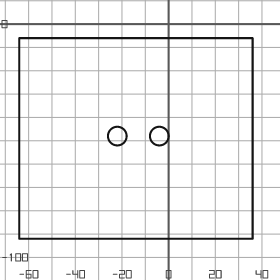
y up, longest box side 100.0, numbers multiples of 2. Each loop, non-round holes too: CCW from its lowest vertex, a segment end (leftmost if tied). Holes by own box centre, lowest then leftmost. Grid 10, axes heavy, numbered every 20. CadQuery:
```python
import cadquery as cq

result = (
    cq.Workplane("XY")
    .moveTo(-64.0, -92.0)
    .lineTo(36.0, -92.0)
    .lineTo(36.0, -6.0)
    .lineTo(-64.0, -6.0)
    .close()
    .moveTo(-22.0, -48.0)
    .circle(4.0)
    .moveTo(-4.0, -48.0)
    .circle(4.0)
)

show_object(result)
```